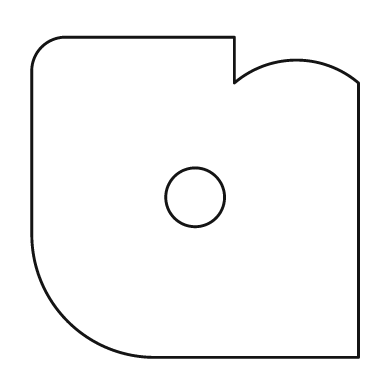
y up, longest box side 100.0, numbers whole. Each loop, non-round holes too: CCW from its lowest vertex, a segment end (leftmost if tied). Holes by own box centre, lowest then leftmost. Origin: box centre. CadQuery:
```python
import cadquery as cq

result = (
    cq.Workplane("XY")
    .moveTo(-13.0, -49.0)
    .lineTo(50.0, -49.0)
    .lineTo(50.0, 35.0)
    .threePointArc((31.0, 42.0), (12.0, 35.0))
    .lineTo(12.0, 49.0)
    .lineTo(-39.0, 49.0)
    .threePointArc((-47.0, 46.0), (-50.0, 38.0))
    .lineTo(-50.0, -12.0)
    .threePointArc((-39.0, -38.0), (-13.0, -49.0))
    .close()
    .moveTo(0.0, 0.0)
    .circle(9.0)
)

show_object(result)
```